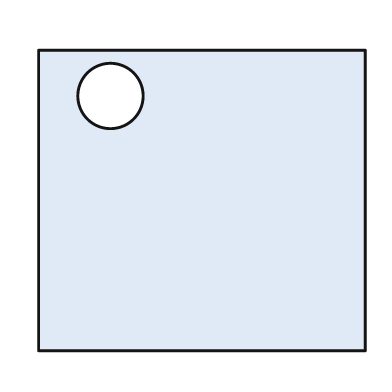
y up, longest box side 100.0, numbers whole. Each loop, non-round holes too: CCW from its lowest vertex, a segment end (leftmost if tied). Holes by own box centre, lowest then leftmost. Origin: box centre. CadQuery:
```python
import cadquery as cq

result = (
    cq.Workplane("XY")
    .moveTo(-50.0, -46.0)
    .lineTo(50.0, -46.0)
    .lineTo(50.0, 46.0)
    .lineTo(-50.0, 46.0)
    .close()
    .moveTo(-28.0, 32.0)
    .circle(10.0)
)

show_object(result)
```